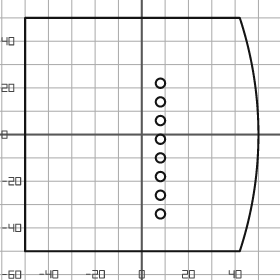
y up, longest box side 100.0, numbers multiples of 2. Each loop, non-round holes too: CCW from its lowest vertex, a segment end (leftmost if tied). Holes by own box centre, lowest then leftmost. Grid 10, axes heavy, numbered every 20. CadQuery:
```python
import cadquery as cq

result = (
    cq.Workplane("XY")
    .moveTo(-50.0, -50.0)
    .lineTo(42.0, -50.0)
    .threePointArc((50.0, 0.0), (42.0, 50.0))
    .lineTo(-50.0, 50.0)
    .close()
    .moveTo(8.0, -34.0)
    .circle(2.0)
    .moveTo(8.0, -26.0)
    .circle(2.0)
    .moveTo(8.0, -18.0)
    .circle(2.0)
    .moveTo(8.0, -10.0)
    .circle(2.0)
    .moveTo(8.0, -2.0)
    .circle(2.0)
    .moveTo(8.0, 6.0)
    .circle(2.0)
    .moveTo(8.0, 14.0)
    .circle(2.0)
    .moveTo(8.0, 22.0)
    .circle(2.0)
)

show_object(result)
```